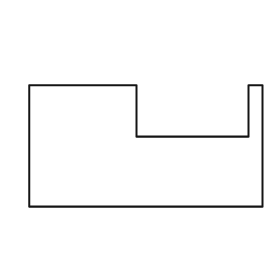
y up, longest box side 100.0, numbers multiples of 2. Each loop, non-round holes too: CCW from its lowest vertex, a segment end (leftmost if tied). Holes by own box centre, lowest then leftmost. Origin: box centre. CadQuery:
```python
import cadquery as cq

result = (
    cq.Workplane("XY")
    .moveTo(-50.0, -26.0)
    .lineTo(50.0, -26.0)
    .lineTo(50.0, 26.0)
    .lineTo(44.0, 26.0)
    .lineTo(44.0, 4.0)
    .lineTo(-4.0, 4.0)
    .lineTo(-4.0, 26.0)
    .lineTo(-50.0, 26.0)
    .close()
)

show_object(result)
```